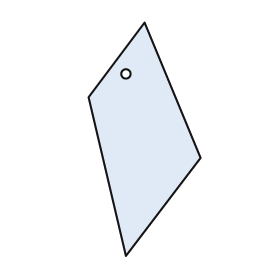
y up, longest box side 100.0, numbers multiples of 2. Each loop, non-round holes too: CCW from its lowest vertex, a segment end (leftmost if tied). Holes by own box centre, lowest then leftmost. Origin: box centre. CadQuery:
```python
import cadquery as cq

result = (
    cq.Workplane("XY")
    .moveTo(-8.0, -50.0)
    .lineTo(24.0, -8.0)
    .lineTo(0.0, 50.0)
    .lineTo(-24.0, 18.0)
    .close()
    .moveTo(-8.0, 28.0)
    .circle(2.0)
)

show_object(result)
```